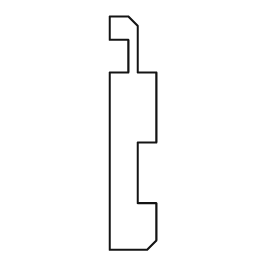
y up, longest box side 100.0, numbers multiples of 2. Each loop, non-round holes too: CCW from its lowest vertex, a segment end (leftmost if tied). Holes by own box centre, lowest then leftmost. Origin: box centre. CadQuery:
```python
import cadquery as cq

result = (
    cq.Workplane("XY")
    .moveTo(-10.0, -50.0)
    .lineTo(6.0, -50.0)
    .lineTo(10.0, -46.0)
    .lineTo(10.0, -30.0)
    .lineTo(2.0, -30.0)
    .lineTo(2.0, -4.0)
    .lineTo(10.0, -4.0)
    .lineTo(10.0, 26.0)
    .lineTo(2.0, 26.0)
    .lineTo(2.0, 46.0)
    .lineTo(-2.0, 50.0)
    .lineTo(-10.0, 50.0)
    .lineTo(-10.0, 40.0)
    .lineTo(-2.0, 40.0)
    .lineTo(-2.0, 26.0)
    .lineTo(-10.0, 26.0)
    .close()
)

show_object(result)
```